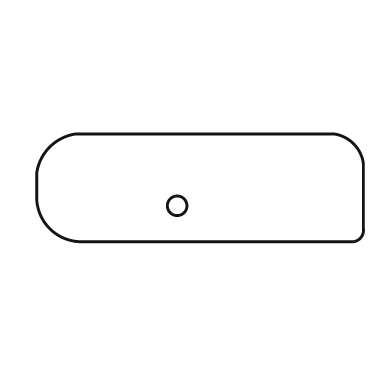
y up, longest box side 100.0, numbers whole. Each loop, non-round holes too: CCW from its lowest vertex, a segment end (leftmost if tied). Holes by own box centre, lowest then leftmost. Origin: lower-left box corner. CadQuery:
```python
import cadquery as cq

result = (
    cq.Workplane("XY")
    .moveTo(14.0, 0.0)
    .lineTo(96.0, 0.0)
    .threePointArc((99.0, 1.0), (100.0, 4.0))
    .lineTo(100.0, 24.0)
    .threePointArc((97.0, 30.0), (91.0, 33.0))
    .lineTo(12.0, 33.0)
    .threePointArc((4.0, 29.0), (0.0, 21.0))
    .lineTo(0.0, 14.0)
    .threePointArc((4.0, 4.0), (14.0, 0.0))
    .close()
    .moveTo(43.0, 11.0)
    .circle(3.0)
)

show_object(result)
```